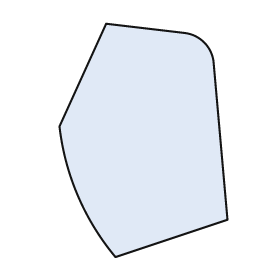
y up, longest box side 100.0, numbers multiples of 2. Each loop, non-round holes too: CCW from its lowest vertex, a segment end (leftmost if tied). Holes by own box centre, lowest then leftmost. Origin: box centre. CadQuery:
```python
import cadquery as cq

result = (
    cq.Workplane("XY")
    .moveTo(-12.0, -50.0)
    .lineTo(36.0, -34.0)
    .lineTo(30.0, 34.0)
    .threePointArc((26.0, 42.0), (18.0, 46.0))
    .lineTo(-16.0, 50.0)
    .lineTo(-36.0, 6.0)
    .threePointArc((-28.0, -24.0), (-12.0, -50.0))
    .close()
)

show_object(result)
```